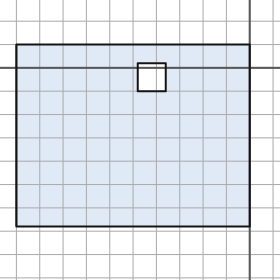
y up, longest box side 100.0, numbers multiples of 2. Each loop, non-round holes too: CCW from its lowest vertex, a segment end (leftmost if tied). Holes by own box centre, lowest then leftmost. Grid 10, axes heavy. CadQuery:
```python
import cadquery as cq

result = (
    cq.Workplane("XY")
    .moveTo(-100.0, -68.0)
    .lineTo(0.0, -68.0)
    .lineTo(0.0, 10.0)
    .lineTo(-100.0, 10.0)
    .close()
    .moveTo(-48.0, -10.0)
    .lineTo(-36.0, -10.0)
    .lineTo(-36.0, 2.0)
    .lineTo(-48.0, 2.0)
    .close()
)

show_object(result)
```